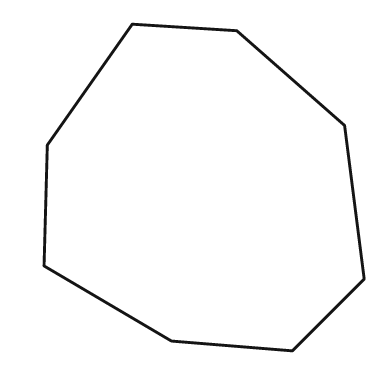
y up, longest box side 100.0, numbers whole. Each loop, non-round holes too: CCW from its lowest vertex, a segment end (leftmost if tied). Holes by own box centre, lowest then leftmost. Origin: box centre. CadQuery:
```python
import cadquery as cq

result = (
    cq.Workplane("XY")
    .moveTo(27.0, -50.0)
    .lineTo(49.0, -28.0)
    .lineTo(43.0, 19.0)
    .lineTo(10.0, 48.0)
    .lineTo(-22.0, 50.0)
    .lineTo(-48.0, 13.0)
    .lineTo(-49.0, -24.0)
    .lineTo(-10.0, -47.0)
    .close()
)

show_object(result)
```